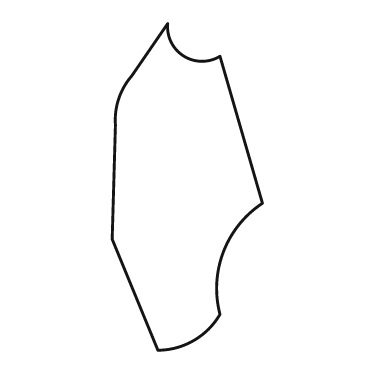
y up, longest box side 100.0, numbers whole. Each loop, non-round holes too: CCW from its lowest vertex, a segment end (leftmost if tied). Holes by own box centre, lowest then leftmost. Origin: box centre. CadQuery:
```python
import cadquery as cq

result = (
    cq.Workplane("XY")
    .moveTo(-9.0, -50.0)
    .threePointArc((2.0, -47.0), (10.0, -39.0))
    .threePointArc((11.0, -20.0), (23.0, -5.0))
    .lineTo(10.0, 40.0)
    .threePointArc((-1.0, 40.0), (-6.0, 50.0))
    .lineTo(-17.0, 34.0)
    .threePointArc((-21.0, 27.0), (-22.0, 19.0))
    .lineTo(-23.0, -16.0)
    .close()
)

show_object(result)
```